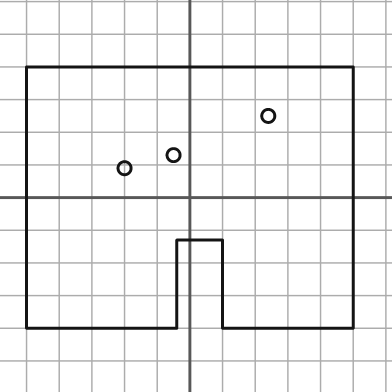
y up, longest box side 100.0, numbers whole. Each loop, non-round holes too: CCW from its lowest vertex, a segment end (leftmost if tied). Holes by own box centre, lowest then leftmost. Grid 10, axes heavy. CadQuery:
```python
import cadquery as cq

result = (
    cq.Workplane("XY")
    .moveTo(-50.0, -40.0)
    .lineTo(-4.0, -40.0)
    .lineTo(-4.0, -13.0)
    .lineTo(10.0, -13.0)
    .lineTo(10.0, -40.0)
    .lineTo(50.0, -40.0)
    .lineTo(50.0, 40.0)
    .lineTo(-50.0, 40.0)
    .close()
    .moveTo(-20.0, 9.0)
    .circle(2.0)
    .moveTo(-5.0, 13.0)
    .circle(2.0)
    .moveTo(24.0, 25.0)
    .circle(2.0)
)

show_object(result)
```